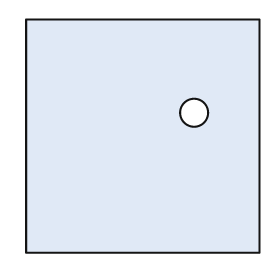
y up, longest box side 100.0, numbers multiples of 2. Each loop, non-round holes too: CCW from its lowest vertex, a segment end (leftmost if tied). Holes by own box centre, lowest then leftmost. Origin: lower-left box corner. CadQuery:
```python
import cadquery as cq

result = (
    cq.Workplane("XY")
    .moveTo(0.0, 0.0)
    .lineTo(100.0, 0.0)
    .lineTo(100.0, 100.0)
    .lineTo(0.0, 100.0)
    .close()
    .moveTo(72.0, 60.0)
    .circle(6.0)
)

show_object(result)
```